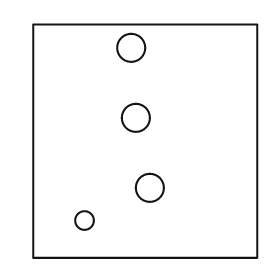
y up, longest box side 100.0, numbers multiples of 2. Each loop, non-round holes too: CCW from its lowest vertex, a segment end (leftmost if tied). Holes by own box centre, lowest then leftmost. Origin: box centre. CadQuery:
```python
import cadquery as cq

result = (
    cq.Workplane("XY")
    .moveTo(-48.0, -50.0)
    .lineTo(48.0, -50.0)
    .lineTo(48.0, 50.0)
    .lineTo(-48.0, 50.0)
    .close()
    .moveTo(-26.0, -34.0)
    .circle(4.0)
    .moveTo(2.0, -20.0)
    .circle(6.0)
    .moveTo(-4.0, 10.0)
    .circle(6.0)
    .moveTo(-6.0, 40.0)
    .circle(6.0)
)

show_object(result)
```